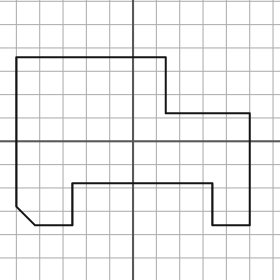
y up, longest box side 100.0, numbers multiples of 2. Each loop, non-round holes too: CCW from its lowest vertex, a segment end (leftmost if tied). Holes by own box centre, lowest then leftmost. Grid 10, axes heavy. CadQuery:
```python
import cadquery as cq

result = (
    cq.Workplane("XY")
    .moveTo(-42.0, -36.0)
    .lineTo(-26.0, -36.0)
    .lineTo(-26.0, -18.0)
    .lineTo(34.0, -18.0)
    .lineTo(34.0, -36.0)
    .lineTo(50.0, -36.0)
    .lineTo(50.0, 12.0)
    .lineTo(14.0, 12.0)
    .lineTo(14.0, 36.0)
    .lineTo(-50.0, 36.0)
    .lineTo(-50.0, -28.0)
    .close()
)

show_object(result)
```